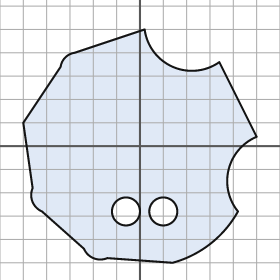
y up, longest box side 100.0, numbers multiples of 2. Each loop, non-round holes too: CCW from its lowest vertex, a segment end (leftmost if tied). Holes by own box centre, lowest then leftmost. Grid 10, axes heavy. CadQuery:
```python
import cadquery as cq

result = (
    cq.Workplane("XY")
    .moveTo(14.0, -50.0)
    .threePointArc((30.0, -42.0), (42.0, -28.0))
    .threePointArc((38.0, -10.0), (50.0, 4.0))
    .lineTo(34.0, 36.0)
    .threePointArc((14.0, 34.0), (2.0, 50.0))
    .lineTo(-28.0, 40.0)
    .threePointArc((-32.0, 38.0), (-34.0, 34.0))
    .lineTo(-50.0, 10.0)
    .lineTo(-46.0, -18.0)
    .threePointArc((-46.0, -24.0), (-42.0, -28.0))
    .lineTo(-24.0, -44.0)
    .threePointArc((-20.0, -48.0), (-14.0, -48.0))
    .close()
    .moveTo(-6.0, -28.0)
    .circle(6.0)
    .moveTo(10.0, -28.0)
    .circle(6.0)
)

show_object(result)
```